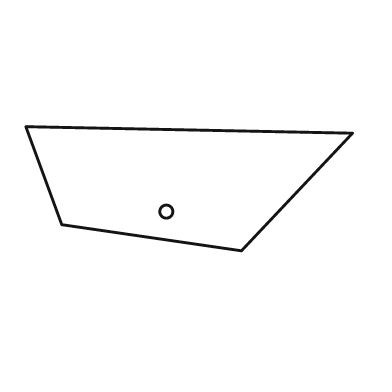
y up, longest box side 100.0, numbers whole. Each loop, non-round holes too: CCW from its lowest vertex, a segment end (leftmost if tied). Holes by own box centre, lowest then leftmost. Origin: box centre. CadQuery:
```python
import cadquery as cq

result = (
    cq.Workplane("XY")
    .moveTo(16.0, -19.0)
    .lineTo(50.0, 17.0)
    .lineTo(-50.0, 19.0)
    .lineTo(-39.0, -11.0)
    .close()
    .moveTo(-7.0, -7.0)
    .circle(2.0)
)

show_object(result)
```